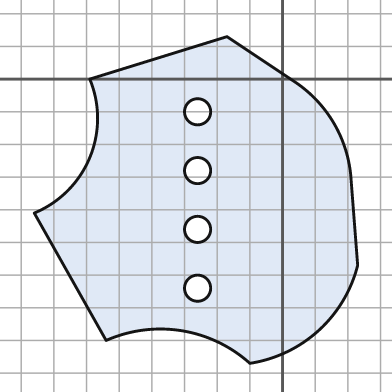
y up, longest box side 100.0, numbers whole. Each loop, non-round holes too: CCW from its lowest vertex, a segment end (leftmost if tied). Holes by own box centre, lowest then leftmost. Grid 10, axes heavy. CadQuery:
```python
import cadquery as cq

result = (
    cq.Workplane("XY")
    .moveTo(-10.0, -87.0)
    .threePointArc((11.0, -77.0), (23.0, -57.0))
    .lineTo(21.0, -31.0)
    .threePointArc((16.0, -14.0), (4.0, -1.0))
    .lineTo(-17.0, 13.0)
    .lineTo(-59.0, 0.0)
    .threePointArc((-59.0, -24.0), (-76.0, -41.0))
    .lineTo(-54.0, -80.0)
    .threePointArc((-31.0, -77.0), (-10.0, -87.0))
    .close()
    .moveTo(-26.0, -64.0)
    .circle(4.0)
    .moveTo(-26.0, -46.0)
    .circle(4.0)
    .moveTo(-26.0, -28.0)
    .circle(4.0)
    .moveTo(-26.0, -10.0)
    .circle(4.0)
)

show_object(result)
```